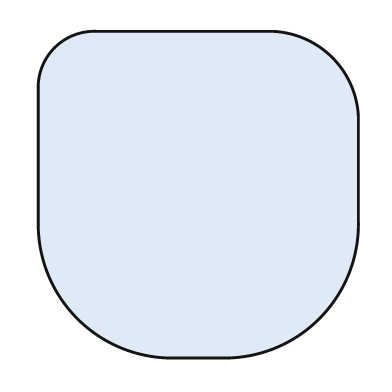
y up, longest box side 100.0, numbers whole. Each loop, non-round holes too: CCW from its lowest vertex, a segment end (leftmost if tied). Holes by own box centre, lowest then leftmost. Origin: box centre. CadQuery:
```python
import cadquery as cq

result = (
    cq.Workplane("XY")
    .moveTo(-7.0, -50.0)
    .lineTo(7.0, -50.0)
    .threePointArc((37.0, -38.0), (49.0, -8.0))
    .lineTo(49.0, 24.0)
    .threePointArc((41.0, 42.0), (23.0, 50.0))
    .lineTo(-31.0, 50.0)
    .threePointArc((-44.0, 45.0), (-49.0, 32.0))
    .lineTo(-49.0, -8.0)
    .threePointArc((-37.0, -38.0), (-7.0, -50.0))
    .close()
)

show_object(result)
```